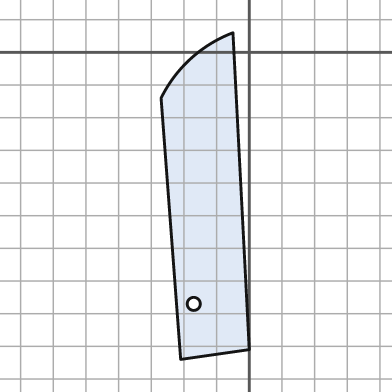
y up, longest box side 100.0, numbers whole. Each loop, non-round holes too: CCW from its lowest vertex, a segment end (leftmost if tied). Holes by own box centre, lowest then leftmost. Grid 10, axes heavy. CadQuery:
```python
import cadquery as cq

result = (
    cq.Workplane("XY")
    .moveTo(-21.0, -94.0)
    .lineTo(0.0, -91.0)
    .lineTo(-5.0, 6.0)
    .threePointArc((-18.0, -2.0), (-27.0, -14.0))
    .close()
    .moveTo(-17.0, -77.0)
    .circle(2.0)
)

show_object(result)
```